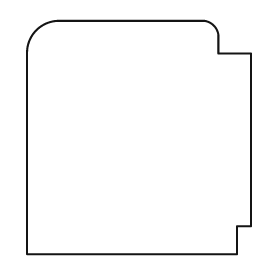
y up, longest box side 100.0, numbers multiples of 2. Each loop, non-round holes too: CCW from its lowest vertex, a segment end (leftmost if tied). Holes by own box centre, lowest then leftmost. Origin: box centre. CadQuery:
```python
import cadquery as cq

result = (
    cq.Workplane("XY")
    .moveTo(-48.0, -50.0)
    .lineTo(42.0, -50.0)
    .lineTo(42.0, -38.0)
    .lineTo(48.0, -38.0)
    .lineTo(48.0, 36.0)
    .lineTo(34.0, 36.0)
    .lineTo(34.0, 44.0)
    .threePointArc((32.0, 48.0), (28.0, 50.0))
    .lineTo(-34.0, 50.0)
    .threePointArc((-44.0, 46.0), (-48.0, 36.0))
    .close()
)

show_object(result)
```